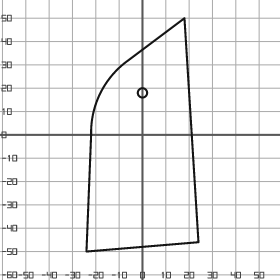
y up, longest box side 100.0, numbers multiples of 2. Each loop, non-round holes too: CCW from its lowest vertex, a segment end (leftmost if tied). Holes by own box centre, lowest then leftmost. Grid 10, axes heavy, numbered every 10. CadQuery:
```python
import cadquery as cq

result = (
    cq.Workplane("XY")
    .moveTo(-24.0, -50.0)
    .lineTo(24.0, -46.0)
    .lineTo(18.0, 50.0)
    .lineTo(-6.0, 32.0)
    .threePointArc((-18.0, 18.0), (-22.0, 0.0))
    .close()
    .moveTo(0.0, 18.0)
    .circle(2.0)
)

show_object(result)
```